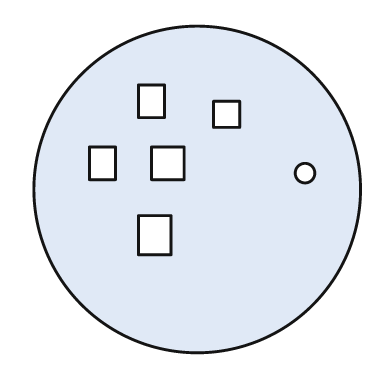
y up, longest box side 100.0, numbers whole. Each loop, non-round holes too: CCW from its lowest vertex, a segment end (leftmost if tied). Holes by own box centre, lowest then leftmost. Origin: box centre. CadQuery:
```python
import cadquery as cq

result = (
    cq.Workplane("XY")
    .moveTo(0.0, 0.0)
    .circle(50.0)
    .moveTo(-18.0, -20.0)
    .lineTo(-8.0, -20.0)
    .lineTo(-8.0, -8.0)
    .lineTo(-18.0, -8.0)
    .close()
    .moveTo(33.0, 5.0)
    .circle(3.0)
    .moveTo(-33.0, 3.0)
    .lineTo(-25.0, 3.0)
    .lineTo(-25.0, 13.0)
    .lineTo(-33.0, 13.0)
    .close()
    .moveTo(-14.0, 3.0)
    .lineTo(-4.0, 3.0)
    .lineTo(-4.0, 13.0)
    .lineTo(-14.0, 13.0)
    .close()
    .moveTo(5.0, 19.0)
    .lineTo(13.0, 19.0)
    .lineTo(13.0, 27.0)
    .lineTo(5.0, 27.0)
    .close()
    .moveTo(-18.0, 22.0)
    .lineTo(-10.0, 22.0)
    .lineTo(-10.0, 32.0)
    .lineTo(-18.0, 32.0)
    .close()
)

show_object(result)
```